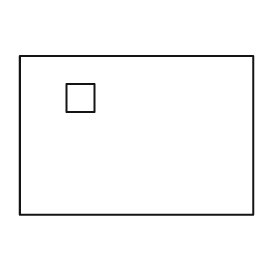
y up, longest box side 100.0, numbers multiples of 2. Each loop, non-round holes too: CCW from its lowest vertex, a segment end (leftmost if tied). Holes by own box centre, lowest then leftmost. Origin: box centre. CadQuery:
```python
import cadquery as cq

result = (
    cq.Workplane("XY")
    .moveTo(-50.0, -34.0)
    .lineTo(50.0, -34.0)
    .lineTo(50.0, 34.0)
    .lineTo(-50.0, 34.0)
    .close()
    .moveTo(-30.0, 10.0)
    .lineTo(-18.0, 10.0)
    .lineTo(-18.0, 22.0)
    .lineTo(-30.0, 22.0)
    .close()
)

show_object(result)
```